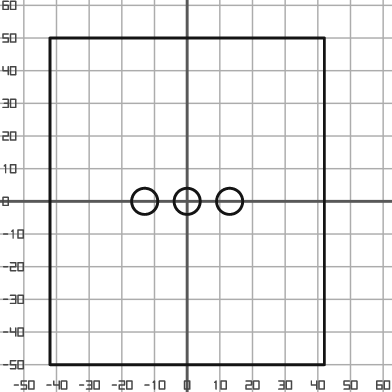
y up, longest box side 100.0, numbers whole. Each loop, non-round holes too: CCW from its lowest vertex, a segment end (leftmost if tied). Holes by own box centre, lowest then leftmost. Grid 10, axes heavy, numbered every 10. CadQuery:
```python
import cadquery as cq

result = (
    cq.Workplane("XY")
    .moveTo(-42.0, -50.0)
    .lineTo(42.0, -50.0)
    .lineTo(42.0, 50.0)
    .lineTo(-42.0, 50.0)
    .close()
    .moveTo(-13.0, 0.0)
    .circle(4.0)
    .moveTo(0.0, 0.0)
    .circle(4.0)
    .moveTo(13.0, 0.0)
    .circle(4.0)
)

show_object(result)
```